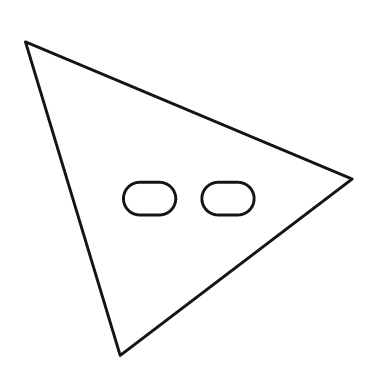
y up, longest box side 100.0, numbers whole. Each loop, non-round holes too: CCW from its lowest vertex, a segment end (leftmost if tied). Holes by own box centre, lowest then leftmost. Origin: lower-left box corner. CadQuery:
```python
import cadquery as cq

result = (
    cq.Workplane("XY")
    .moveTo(29.0, 0.0)
    .lineTo(100.0, 54.0)
    .lineTo(0.0, 96.0)
    .close()
    .moveTo(35.0, 43.0)
    .lineTo(41.0, 43.0)
    .threePointArc((46.0, 48.0), (41.0, 53.0))
    .lineTo(35.0, 53.0)
    .threePointArc((30.0, 48.0), (35.0, 43.0))
    .close()
    .moveTo(59.0, 43.0)
    .lineTo(65.0, 43.0)
    .threePointArc((70.0, 48.0), (65.0, 53.0))
    .lineTo(59.0, 53.0)
    .threePointArc((54.0, 48.0), (59.0, 43.0))
    .close()
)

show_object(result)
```